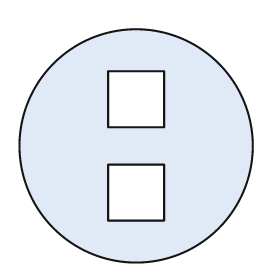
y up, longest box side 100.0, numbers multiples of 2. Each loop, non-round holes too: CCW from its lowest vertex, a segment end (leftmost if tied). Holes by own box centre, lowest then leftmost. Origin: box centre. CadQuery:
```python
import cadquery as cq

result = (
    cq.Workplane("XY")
    .moveTo(0.0, 0.0)
    .circle(50.0)
    .moveTo(-12.0, -32.0)
    .lineTo(12.0, -32.0)
    .lineTo(12.0, -8.0)
    .lineTo(-12.0, -8.0)
    .close()
    .moveTo(-12.0, 8.0)
    .lineTo(12.0, 8.0)
    .lineTo(12.0, 32.0)
    .lineTo(-12.0, 32.0)
    .close()
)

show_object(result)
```